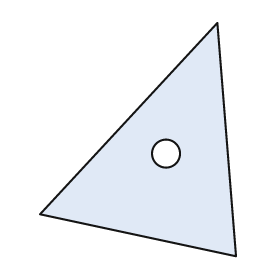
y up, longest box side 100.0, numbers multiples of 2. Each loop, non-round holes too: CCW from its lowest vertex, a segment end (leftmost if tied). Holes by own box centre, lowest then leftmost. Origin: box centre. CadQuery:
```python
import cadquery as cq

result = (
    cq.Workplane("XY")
    .moveTo(42.0, -50.0)
    .lineTo(34.0, 50.0)
    .lineTo(-42.0, -32.0)
    .close()
    .moveTo(12.0, -6.0)
    .circle(6.0)
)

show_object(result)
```